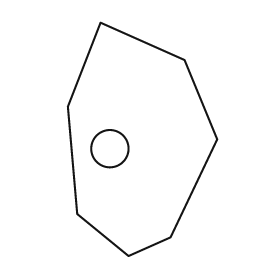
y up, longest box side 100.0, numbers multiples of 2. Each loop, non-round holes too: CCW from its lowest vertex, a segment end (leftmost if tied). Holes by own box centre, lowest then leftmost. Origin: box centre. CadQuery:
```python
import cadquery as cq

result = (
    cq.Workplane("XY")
    .moveTo(-6.0, -50.0)
    .lineTo(12.0, -42.0)
    .lineTo(32.0, 0.0)
    .lineTo(18.0, 34.0)
    .lineTo(-18.0, 50.0)
    .lineTo(-32.0, 14.0)
    .lineTo(-28.0, -32.0)
    .close()
    .moveTo(-14.0, -4.0)
    .circle(8.0)
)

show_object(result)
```